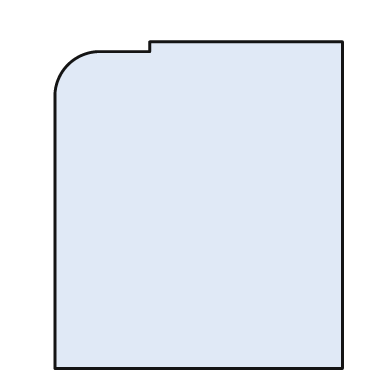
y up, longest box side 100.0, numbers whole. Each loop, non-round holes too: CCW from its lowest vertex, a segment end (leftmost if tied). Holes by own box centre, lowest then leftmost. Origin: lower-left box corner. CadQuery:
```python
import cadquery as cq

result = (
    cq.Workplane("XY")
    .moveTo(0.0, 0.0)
    .lineTo(88.0, 0.0)
    .lineTo(88.0, 100.0)
    .lineTo(29.0, 100.0)
    .lineTo(29.0, 97.0)
    .lineTo(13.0, 97.0)
    .threePointArc((4.0, 93.0), (0.0, 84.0))
    .close()
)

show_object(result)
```